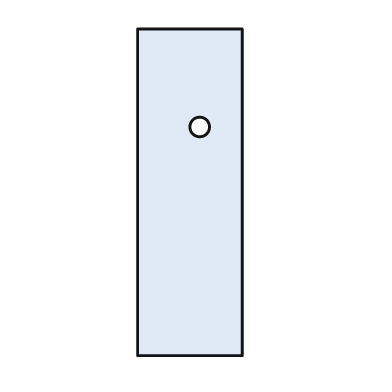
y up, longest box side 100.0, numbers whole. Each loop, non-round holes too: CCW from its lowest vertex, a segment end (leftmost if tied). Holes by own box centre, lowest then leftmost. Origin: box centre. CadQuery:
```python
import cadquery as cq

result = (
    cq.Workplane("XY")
    .moveTo(-16.0, -50.0)
    .lineTo(16.0, -50.0)
    .lineTo(16.0, 50.0)
    .lineTo(-16.0, 50.0)
    .close()
    .moveTo(3.0, 20.0)
    .circle(3.0)
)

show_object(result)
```